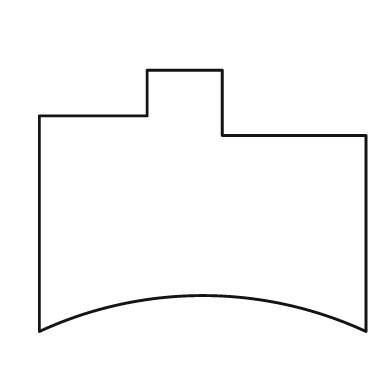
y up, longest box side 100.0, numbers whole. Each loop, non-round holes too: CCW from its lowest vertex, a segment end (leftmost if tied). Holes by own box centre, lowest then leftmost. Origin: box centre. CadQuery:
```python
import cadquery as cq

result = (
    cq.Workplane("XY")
    .moveTo(-50.0, -40.0)
    .threePointArc((0.0, -29.0), (50.0, -40.0))
    .lineTo(50.0, 20.0)
    .lineTo(6.0, 20.0)
    .lineTo(6.0, 40.0)
    .lineTo(-17.0, 40.0)
    .lineTo(-17.0, 26.0)
    .lineTo(-50.0, 26.0)
    .close()
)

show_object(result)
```